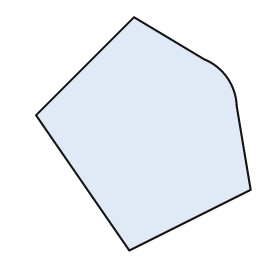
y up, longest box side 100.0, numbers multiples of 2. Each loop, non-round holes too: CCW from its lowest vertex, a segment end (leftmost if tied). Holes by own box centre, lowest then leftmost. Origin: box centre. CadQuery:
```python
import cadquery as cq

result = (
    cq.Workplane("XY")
    .moveTo(-6.0, -50.0)
    .lineTo(46.0, -24.0)
    .lineTo(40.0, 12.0)
    .threePointArc((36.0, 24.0), (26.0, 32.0))
    .lineTo(-4.0, 50.0)
    .lineTo(-46.0, 8.0)
    .close()
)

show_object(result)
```